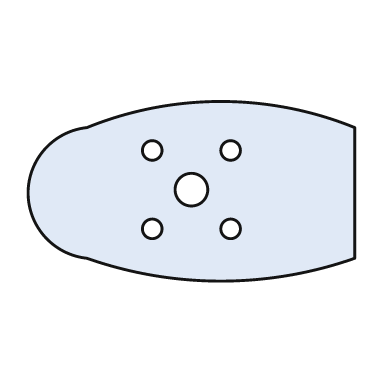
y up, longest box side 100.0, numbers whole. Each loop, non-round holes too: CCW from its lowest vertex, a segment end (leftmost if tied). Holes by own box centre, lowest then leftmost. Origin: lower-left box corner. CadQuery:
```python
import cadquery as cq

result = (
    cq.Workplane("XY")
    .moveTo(18.0, 7.0)
    .threePointArc((59.0, 0.0), (100.0, 7.0))
    .lineTo(100.0, 47.0)
    .threePointArc((59.0, 55.0), (18.0, 47.0))
    .threePointArc((0.0, 27.0), (18.0, 7.0))
    .close()
    .moveTo(38.0, 16.0)
    .circle(3.0)
    .moveTo(62.0, 16.0)
    .circle(3.0)
    .moveTo(50.0, 28.0)
    .circle(5.0)
    .moveTo(38.0, 40.0)
    .circle(3.0)
    .moveTo(62.0, 40.0)
    .circle(3.0)
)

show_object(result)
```